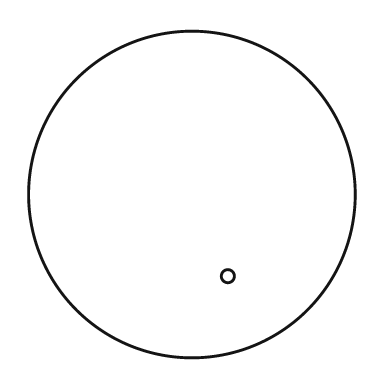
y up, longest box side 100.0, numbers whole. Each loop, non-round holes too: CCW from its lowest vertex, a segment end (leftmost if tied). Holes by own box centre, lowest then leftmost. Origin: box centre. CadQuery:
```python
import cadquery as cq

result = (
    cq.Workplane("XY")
    .moveTo(0.0, 0.0)
    .circle(50.0)
    .moveTo(11.0, -25.0)
    .circle(2.0)
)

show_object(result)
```